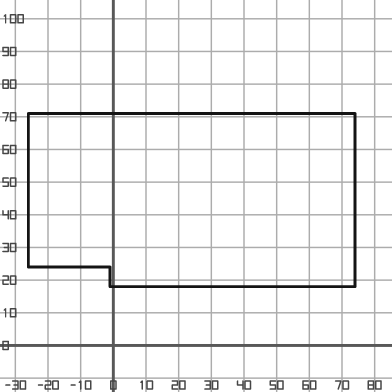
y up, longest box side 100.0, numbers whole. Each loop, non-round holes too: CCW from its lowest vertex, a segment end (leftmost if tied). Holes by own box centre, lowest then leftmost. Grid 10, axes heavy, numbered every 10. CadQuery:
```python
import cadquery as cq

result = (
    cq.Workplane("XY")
    .moveTo(-1.0, 18.0)
    .lineTo(74.0, 18.0)
    .lineTo(74.0, 71.0)
    .lineTo(-26.0, 71.0)
    .lineTo(-26.0, 24.0)
    .lineTo(-1.0, 24.0)
    .close()
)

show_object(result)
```